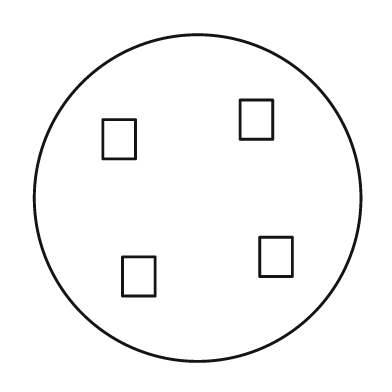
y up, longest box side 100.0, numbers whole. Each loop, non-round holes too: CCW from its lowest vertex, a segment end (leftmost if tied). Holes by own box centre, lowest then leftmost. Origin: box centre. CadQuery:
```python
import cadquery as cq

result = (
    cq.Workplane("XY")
    .moveTo(0.0, 0.0)
    .circle(50.0)
    .moveTo(-23.0, -30.0)
    .lineTo(-13.0, -30.0)
    .lineTo(-13.0, -18.0)
    .lineTo(-23.0, -18.0)
    .close()
    .moveTo(19.0, -24.0)
    .lineTo(29.0, -24.0)
    .lineTo(29.0, -12.0)
    .lineTo(19.0, -12.0)
    .close()
    .moveTo(-29.0, 12.0)
    .lineTo(-19.0, 12.0)
    .lineTo(-19.0, 24.0)
    .lineTo(-29.0, 24.0)
    .close()
    .moveTo(13.0, 18.0)
    .lineTo(23.0, 18.0)
    .lineTo(23.0, 30.0)
    .lineTo(13.0, 30.0)
    .close()
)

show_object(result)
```